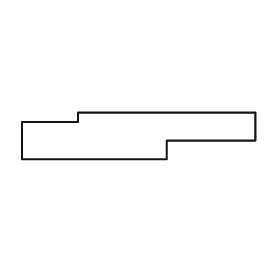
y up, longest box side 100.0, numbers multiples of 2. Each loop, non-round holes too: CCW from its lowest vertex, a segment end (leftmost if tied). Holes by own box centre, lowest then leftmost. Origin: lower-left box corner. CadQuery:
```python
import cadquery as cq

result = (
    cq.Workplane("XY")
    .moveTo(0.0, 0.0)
    .lineTo(62.0, 0.0)
    .lineTo(62.0, 8.0)
    .lineTo(100.0, 8.0)
    .lineTo(100.0, 20.0)
    .lineTo(24.0, 20.0)
    .lineTo(24.0, 16.0)
    .lineTo(0.0, 16.0)
    .close()
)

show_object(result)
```